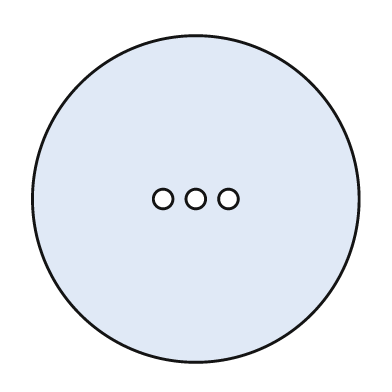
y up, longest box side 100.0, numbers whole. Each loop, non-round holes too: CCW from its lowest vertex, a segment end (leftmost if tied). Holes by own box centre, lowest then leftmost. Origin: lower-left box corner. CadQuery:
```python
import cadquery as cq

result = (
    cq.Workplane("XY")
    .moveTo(50.0, 50.0)
    .circle(50.0)
    .moveTo(40.0, 50.0)
    .circle(3.0)
    .moveTo(50.0, 50.0)
    .circle(3.0)
    .moveTo(60.0, 50.0)
    .circle(3.0)
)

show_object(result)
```